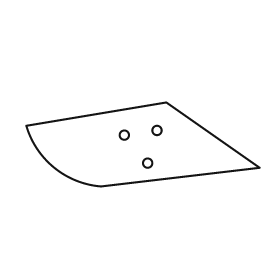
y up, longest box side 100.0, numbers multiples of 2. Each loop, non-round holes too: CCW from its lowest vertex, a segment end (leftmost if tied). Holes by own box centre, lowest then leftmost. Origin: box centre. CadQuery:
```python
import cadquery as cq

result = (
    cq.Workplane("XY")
    .moveTo(-18.0, -18.0)
    .lineTo(50.0, -10.0)
    .lineTo(10.0, 18.0)
    .lineTo(-50.0, 8.0)
    .threePointArc((-38.0, -10.0), (-18.0, -18.0))
    .close()
    .moveTo(2.0, -8.0)
    .circle(2.0)
    .moveTo(-8.0, 4.0)
    .circle(2.0)
    .moveTo(6.0, 6.0)
    .circle(2.0)
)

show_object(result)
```